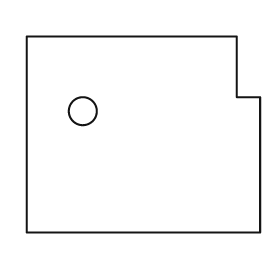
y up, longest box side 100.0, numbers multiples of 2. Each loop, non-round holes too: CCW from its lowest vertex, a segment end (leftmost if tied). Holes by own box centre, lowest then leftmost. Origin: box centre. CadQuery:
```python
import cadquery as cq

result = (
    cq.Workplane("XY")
    .moveTo(-50.0, -42.0)
    .lineTo(50.0, -42.0)
    .lineTo(50.0, 16.0)
    .lineTo(40.0, 16.0)
    .lineTo(40.0, 42.0)
    .lineTo(-50.0, 42.0)
    .close()
    .moveTo(-26.0, 10.0)
    .circle(6.0)
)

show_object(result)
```